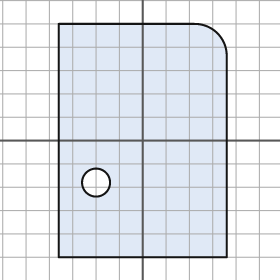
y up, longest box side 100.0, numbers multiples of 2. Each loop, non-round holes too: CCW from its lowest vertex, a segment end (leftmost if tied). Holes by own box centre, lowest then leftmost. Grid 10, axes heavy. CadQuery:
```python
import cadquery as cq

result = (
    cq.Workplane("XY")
    .moveTo(-36.0, -50.0)
    .lineTo(36.0, -50.0)
    .lineTo(36.0, 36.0)
    .threePointArc((32.0, 46.0), (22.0, 50.0))
    .lineTo(-36.0, 50.0)
    .close()
    .moveTo(-20.0, -18.0)
    .circle(6.0)
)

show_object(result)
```